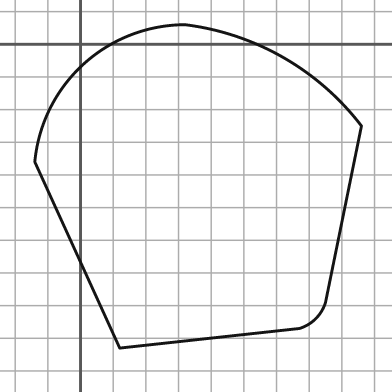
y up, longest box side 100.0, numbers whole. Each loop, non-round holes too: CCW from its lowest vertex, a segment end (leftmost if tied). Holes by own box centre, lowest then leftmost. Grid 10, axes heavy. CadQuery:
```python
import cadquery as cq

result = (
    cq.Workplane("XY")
    .moveTo(12.0, -93.0)
    .lineTo(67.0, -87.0)
    .threePointArc((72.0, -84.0), (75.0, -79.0))
    .lineTo(86.0, -25.0)
    .threePointArc((62.0, -4.0), (32.0, 6.0))
    .threePointArc((1.0, -6.0), (-14.0, -36.0))
    .close()
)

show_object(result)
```